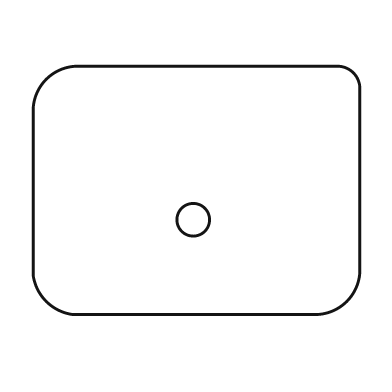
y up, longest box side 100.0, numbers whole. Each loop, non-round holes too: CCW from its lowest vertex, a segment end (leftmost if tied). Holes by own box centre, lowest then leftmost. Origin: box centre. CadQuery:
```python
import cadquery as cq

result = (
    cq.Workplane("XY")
    .moveTo(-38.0, -38.0)
    .lineTo(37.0, -38.0)
    .threePointArc((46.0, -34.0), (50.0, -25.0))
    .lineTo(50.0, 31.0)
    .threePointArc((48.0, 36.0), (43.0, 38.0))
    .lineTo(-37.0, 38.0)
    .threePointArc((-46.0, 34.0), (-50.0, 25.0))
    .lineTo(-50.0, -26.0)
    .threePointArc((-46.0, -34.0), (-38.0, -38.0))
    .close()
    .moveTo(-1.0, -9.0)
    .circle(5.0)
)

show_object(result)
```